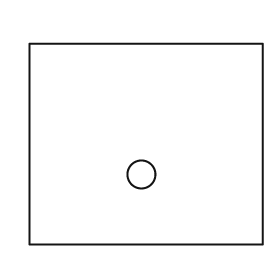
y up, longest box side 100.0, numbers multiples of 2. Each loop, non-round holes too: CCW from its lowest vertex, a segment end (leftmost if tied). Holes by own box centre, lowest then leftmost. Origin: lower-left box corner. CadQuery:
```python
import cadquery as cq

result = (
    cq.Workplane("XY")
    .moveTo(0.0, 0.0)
    .lineTo(100.0, 0.0)
    .lineTo(100.0, 86.0)
    .lineTo(0.0, 86.0)
    .close()
    .moveTo(48.0, 30.0)
    .circle(6.0)
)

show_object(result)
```